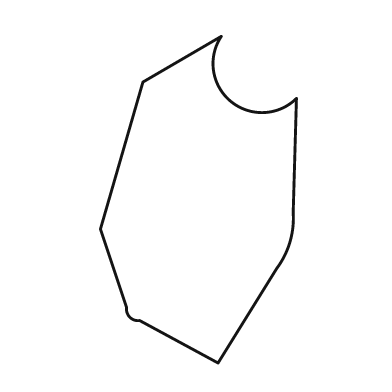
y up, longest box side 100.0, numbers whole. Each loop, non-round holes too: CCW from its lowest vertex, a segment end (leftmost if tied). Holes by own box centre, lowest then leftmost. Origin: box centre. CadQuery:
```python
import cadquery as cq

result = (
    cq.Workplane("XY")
    .moveTo(6.0, -50.0)
    .lineTo(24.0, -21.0)
    .threePointArc((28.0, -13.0), (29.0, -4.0))
    .lineTo(30.0, 31.0)
    .threePointArc((10.0, 30.0), (7.0, 50.0))
    .lineTo(-17.0, 36.0)
    .lineTo(-30.0, -9.0)
    .lineTo(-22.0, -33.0)
    .threePointArc((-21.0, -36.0), (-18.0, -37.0))
    .close()
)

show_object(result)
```